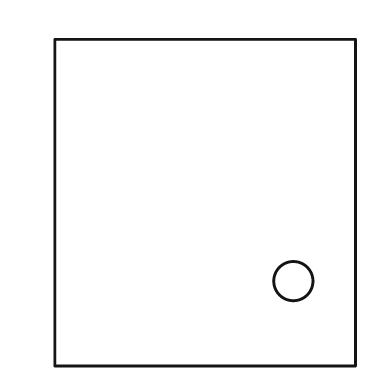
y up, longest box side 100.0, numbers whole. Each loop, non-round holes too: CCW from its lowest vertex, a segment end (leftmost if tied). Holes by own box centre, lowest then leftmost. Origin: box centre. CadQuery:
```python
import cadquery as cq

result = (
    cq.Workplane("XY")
    .moveTo(-46.0, -50.0)
    .lineTo(46.0, -50.0)
    .lineTo(46.0, 50.0)
    .lineTo(-46.0, 50.0)
    .close()
    .moveTo(27.0, -24.0)
    .circle(6.0)
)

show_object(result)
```